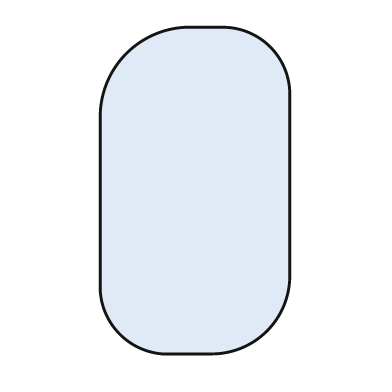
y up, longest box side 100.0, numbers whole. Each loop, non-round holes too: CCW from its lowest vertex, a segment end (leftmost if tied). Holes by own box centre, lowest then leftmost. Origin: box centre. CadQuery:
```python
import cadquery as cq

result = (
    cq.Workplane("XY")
    .moveTo(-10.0, -50.0)
    .lineTo(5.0, -50.0)
    .threePointArc((22.0, -43.0), (29.0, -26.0))
    .lineTo(29.0, 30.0)
    .threePointArc((23.0, 44.0), (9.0, 50.0))
    .lineTo(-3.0, 50.0)
    .threePointArc((-21.0, 42.0), (-29.0, 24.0))
    .lineTo(-29.0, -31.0)
    .threePointArc((-23.0, -44.0), (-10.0, -50.0))
    .close()
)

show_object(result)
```